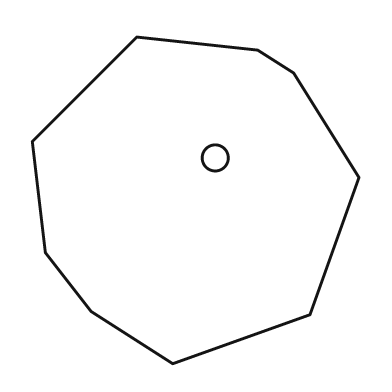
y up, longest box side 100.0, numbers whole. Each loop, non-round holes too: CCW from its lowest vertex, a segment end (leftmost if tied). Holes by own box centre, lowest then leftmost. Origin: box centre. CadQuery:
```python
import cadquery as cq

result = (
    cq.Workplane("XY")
    .moveTo(-7.0, -50.0)
    .lineTo(35.0, -35.0)
    .lineTo(50.0, 7.0)
    .lineTo(30.0, 39.0)
    .lineTo(19.0, 46.0)
    .lineTo(-18.0, 50.0)
    .lineTo(-50.0, 18.0)
    .lineTo(-46.0, -16.0)
    .lineTo(-32.0, -34.0)
    .close()
    .moveTo(6.0, 13.0)
    .circle(4.0)
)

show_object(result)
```